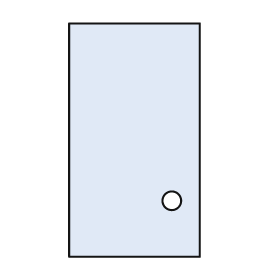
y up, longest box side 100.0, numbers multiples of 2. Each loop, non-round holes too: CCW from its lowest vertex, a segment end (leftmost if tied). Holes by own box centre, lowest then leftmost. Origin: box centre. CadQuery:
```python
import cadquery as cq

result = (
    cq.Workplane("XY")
    .moveTo(-28.0, -50.0)
    .lineTo(28.0, -50.0)
    .lineTo(28.0, 50.0)
    .lineTo(-28.0, 50.0)
    .close()
    .moveTo(16.0, -26.0)
    .circle(4.0)
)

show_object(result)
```